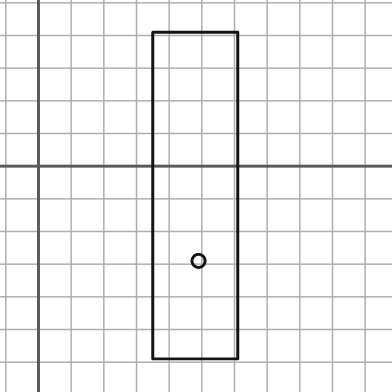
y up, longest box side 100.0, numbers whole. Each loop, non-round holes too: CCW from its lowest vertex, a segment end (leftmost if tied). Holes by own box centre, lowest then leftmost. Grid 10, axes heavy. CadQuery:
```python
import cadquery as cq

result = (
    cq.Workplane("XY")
    .moveTo(35.0, -59.0)
    .lineTo(61.0, -59.0)
    .lineTo(61.0, 41.0)
    .lineTo(35.0, 41.0)
    .close()
    .moveTo(49.0, -29.0)
    .circle(2.0)
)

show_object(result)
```